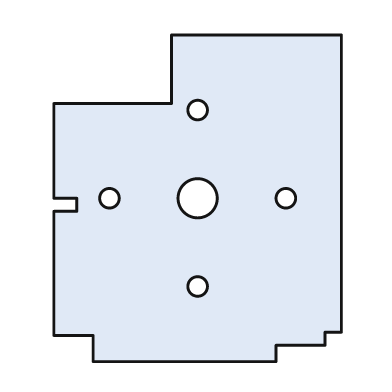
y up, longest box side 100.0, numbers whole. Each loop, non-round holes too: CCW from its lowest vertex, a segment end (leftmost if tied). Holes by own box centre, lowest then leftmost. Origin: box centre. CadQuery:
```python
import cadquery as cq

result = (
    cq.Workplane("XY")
    .moveTo(-32.0, -50.0)
    .lineTo(24.0, -50.0)
    .lineTo(24.0, -45.0)
    .lineTo(39.0, -45.0)
    .lineTo(39.0, -41.0)
    .lineTo(44.0, -41.0)
    .lineTo(44.0, 50.0)
    .lineTo(-8.0, 50.0)
    .lineTo(-8.0, 29.0)
    .lineTo(-44.0, 29.0)
    .lineTo(-44.0, 0.0)
    .lineTo(-37.0, 0.0)
    .lineTo(-37.0, -4.0)
    .lineTo(-44.0, -4.0)
    .lineTo(-44.0, -42.0)
    .lineTo(-32.0, -42.0)
    .close()
    .moveTo(0.0, -27.0)
    .circle(3.0)
    .moveTo(-27.0, 0.0)
    .circle(3.0)
    .moveTo(0.0, 0.0)
    .circle(6.0)
    .moveTo(27.0, 0.0)
    .circle(3.0)
    .moveTo(0.0, 27.0)
    .circle(3.0)
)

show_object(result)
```